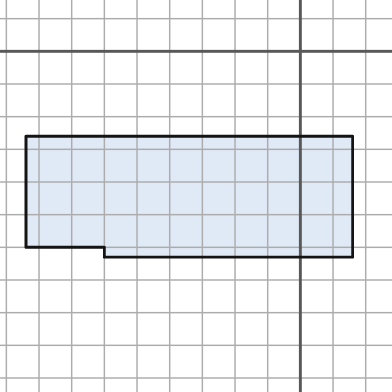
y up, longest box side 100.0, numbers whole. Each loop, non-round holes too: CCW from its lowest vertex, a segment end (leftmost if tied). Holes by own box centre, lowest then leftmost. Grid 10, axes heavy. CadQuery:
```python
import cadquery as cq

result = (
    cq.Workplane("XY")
    .moveTo(-60.0, -63.0)
    .lineTo(16.0, -63.0)
    .lineTo(16.0, -26.0)
    .lineTo(-84.0, -26.0)
    .lineTo(-84.0, -60.0)
    .lineTo(-60.0, -60.0)
    .close()
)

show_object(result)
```